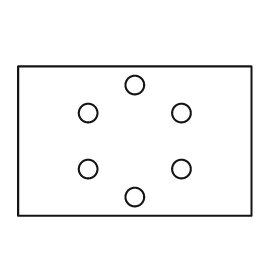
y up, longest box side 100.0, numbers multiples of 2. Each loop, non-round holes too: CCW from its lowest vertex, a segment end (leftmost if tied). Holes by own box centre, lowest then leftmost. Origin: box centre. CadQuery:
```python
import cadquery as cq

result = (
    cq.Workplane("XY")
    .moveTo(-50.0, -32.0)
    .lineTo(50.0, -32.0)
    .lineTo(50.0, 32.0)
    .lineTo(-50.0, 32.0)
    .close()
    .moveTo(0.0, -24.0)
    .circle(4.0)
    .moveTo(-20.0, -12.0)
    .circle(4.0)
    .moveTo(20.0, -12.0)
    .circle(4.0)
    .moveTo(-20.0, 12.0)
    .circle(4.0)
    .moveTo(20.0, 12.0)
    .circle(4.0)
    .moveTo(0.0, 24.0)
    .circle(4.0)
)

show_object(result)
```